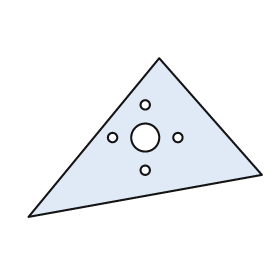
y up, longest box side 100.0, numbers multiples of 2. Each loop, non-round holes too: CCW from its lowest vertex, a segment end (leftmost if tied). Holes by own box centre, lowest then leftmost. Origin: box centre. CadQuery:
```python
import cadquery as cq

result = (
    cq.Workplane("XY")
    .moveTo(-50.0, -34.0)
    .lineTo(50.0, -16.0)
    .lineTo(6.0, 34.0)
    .close()
    .moveTo(0.0, -14.0)
    .circle(2.0)
    .moveTo(-14.0, 0.0)
    .circle(2.0)
    .moveTo(0.0, 0.0)
    .circle(6.0)
    .moveTo(14.0, 0.0)
    .circle(2.0)
    .moveTo(0.0, 14.0)
    .circle(2.0)
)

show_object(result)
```